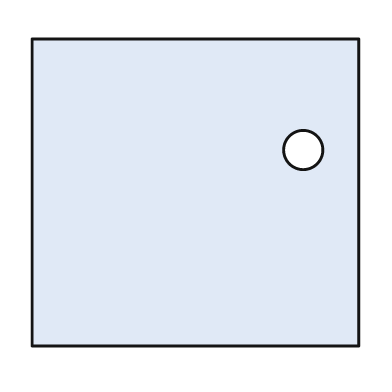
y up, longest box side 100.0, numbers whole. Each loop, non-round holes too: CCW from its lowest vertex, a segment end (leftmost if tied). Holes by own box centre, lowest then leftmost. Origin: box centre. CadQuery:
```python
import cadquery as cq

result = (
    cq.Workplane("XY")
    .moveTo(-50.0, -47.0)
    .lineTo(50.0, -47.0)
    .lineTo(50.0, 47.0)
    .lineTo(-50.0, 47.0)
    .close()
    .moveTo(33.0, 13.0)
    .circle(6.0)
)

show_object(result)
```